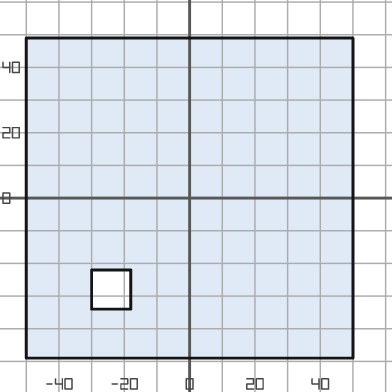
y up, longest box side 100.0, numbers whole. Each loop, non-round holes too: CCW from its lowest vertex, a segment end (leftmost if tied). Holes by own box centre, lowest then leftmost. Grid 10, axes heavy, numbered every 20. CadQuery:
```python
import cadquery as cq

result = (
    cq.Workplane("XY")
    .moveTo(-50.0, -49.0)
    .lineTo(50.0, -49.0)
    .lineTo(50.0, 49.0)
    .lineTo(-50.0, 49.0)
    .close()
    .moveTo(-30.0, -34.0)
    .lineTo(-18.0, -34.0)
    .lineTo(-18.0, -22.0)
    .lineTo(-30.0, -22.0)
    .close()
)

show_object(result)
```